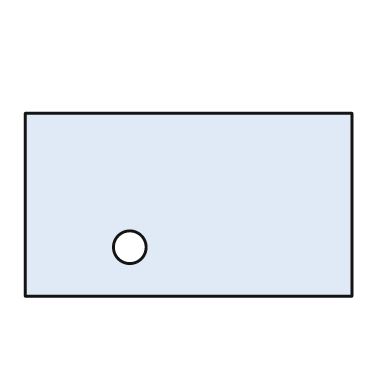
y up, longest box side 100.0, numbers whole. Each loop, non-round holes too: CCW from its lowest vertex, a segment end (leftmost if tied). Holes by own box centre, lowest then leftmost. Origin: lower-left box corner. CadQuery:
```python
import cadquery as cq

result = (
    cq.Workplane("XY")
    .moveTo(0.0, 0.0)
    .lineTo(100.0, 0.0)
    .lineTo(100.0, 56.0)
    .lineTo(0.0, 56.0)
    .close()
    .moveTo(32.0, 15.0)
    .circle(5.0)
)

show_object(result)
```